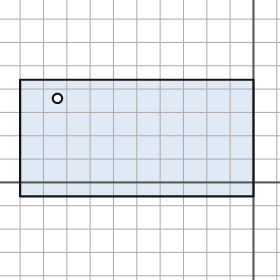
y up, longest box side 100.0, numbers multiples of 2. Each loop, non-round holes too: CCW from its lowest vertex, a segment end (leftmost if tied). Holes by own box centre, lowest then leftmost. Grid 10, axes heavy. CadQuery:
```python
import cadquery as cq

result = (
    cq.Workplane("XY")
    .moveTo(-100.0, -6.0)
    .lineTo(0.0, -6.0)
    .lineTo(0.0, 44.0)
    .lineTo(-100.0, 44.0)
    .close()
    .moveTo(-84.0, 36.0)
    .circle(2.0)
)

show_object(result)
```